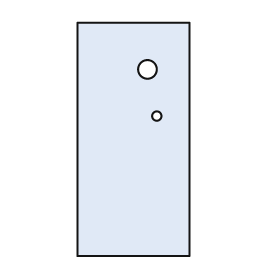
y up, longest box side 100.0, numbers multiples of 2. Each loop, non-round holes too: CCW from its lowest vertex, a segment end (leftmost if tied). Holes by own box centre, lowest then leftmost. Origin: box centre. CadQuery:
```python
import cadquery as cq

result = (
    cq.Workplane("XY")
    .moveTo(-24.0, -50.0)
    .lineTo(24.0, -50.0)
    .lineTo(24.0, 50.0)
    .lineTo(-24.0, 50.0)
    .close()
    .moveTo(10.0, 10.0)
    .circle(2.0)
    .moveTo(6.0, 30.0)
    .circle(4.0)
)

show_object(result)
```